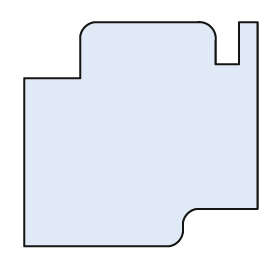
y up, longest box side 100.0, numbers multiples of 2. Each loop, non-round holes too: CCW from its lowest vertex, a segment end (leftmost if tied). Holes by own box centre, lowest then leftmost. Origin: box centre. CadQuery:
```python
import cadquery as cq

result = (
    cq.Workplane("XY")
    .moveTo(-50.0, -48.0)
    .lineTo(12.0, -48.0)
    .threePointArc((16.0, -46.0), (18.0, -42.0))
    .lineTo(18.0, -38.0)
    .threePointArc((20.0, -34.0), (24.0, -32.0))
    .lineTo(50.0, -32.0)
    .lineTo(50.0, 48.0)
    .lineTo(42.0, 48.0)
    .lineTo(42.0, 30.0)
    .lineTo(32.0, 30.0)
    .lineTo(32.0, 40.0)
    .threePointArc((30.0, 46.0), (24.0, 48.0))
    .lineTo(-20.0, 48.0)
    .threePointArc((-24.0, 46.0), (-26.0, 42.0))
    .lineTo(-26.0, 24.0)
    .lineTo(-50.0, 24.0)
    .close()
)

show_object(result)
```